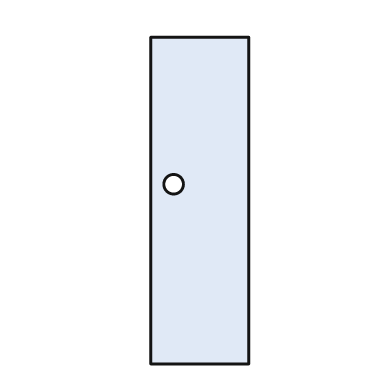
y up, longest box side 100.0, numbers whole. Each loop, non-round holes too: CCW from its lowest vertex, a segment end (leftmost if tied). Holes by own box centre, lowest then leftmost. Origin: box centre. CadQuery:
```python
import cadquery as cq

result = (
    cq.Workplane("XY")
    .moveTo(-15.0, -50.0)
    .lineTo(15.0, -50.0)
    .lineTo(15.0, 50.0)
    .lineTo(-15.0, 50.0)
    .close()
    .moveTo(-8.0, 5.0)
    .circle(3.0)
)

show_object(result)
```